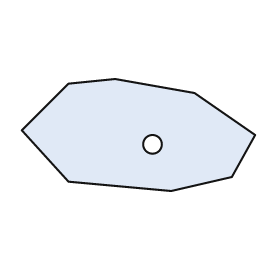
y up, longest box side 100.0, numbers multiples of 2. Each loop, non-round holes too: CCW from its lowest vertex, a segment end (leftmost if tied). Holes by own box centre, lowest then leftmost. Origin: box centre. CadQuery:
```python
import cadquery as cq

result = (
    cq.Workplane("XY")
    .moveTo(14.0, -24.0)
    .lineTo(40.0, -18.0)
    .lineTo(50.0, 0.0)
    .lineTo(24.0, 18.0)
    .lineTo(-10.0, 24.0)
    .lineTo(-30.0, 22.0)
    .lineTo(-50.0, 2.0)
    .lineTo(-30.0, -20.0)
    .close()
    .moveTo(6.0, -4.0)
    .circle(4.0)
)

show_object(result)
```